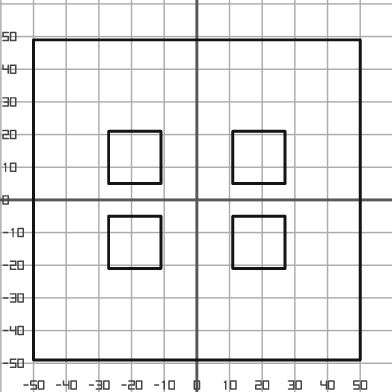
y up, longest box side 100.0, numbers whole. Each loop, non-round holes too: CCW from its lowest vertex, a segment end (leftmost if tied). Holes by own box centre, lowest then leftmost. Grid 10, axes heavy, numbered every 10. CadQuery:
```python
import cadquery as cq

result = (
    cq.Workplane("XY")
    .moveTo(-50.0, -49.0)
    .lineTo(50.0, -49.0)
    .lineTo(50.0, 49.0)
    .lineTo(-50.0, 49.0)
    .close()
    .moveTo(-27.0, -21.0)
    .lineTo(-11.0, -21.0)
    .lineTo(-11.0, -5.0)
    .lineTo(-27.0, -5.0)
    .close()
    .moveTo(11.0, -21.0)
    .lineTo(27.0, -21.0)
    .lineTo(27.0, -5.0)
    .lineTo(11.0, -5.0)
    .close()
    .moveTo(-27.0, 5.0)
    .lineTo(-11.0, 5.0)
    .lineTo(-11.0, 21.0)
    .lineTo(-27.0, 21.0)
    .close()
    .moveTo(11.0, 5.0)
    .lineTo(27.0, 5.0)
    .lineTo(27.0, 21.0)
    .lineTo(11.0, 21.0)
    .close()
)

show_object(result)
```